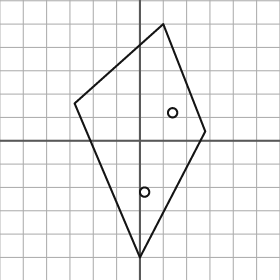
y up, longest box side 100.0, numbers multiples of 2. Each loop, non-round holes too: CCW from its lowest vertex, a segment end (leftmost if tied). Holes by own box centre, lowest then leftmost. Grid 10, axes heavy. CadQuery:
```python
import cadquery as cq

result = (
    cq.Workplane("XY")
    .moveTo(0.0, -50.0)
    .lineTo(28.0, 4.0)
    .lineTo(10.0, 50.0)
    .lineTo(-28.0, 16.0)
    .close()
    .moveTo(2.0, -22.0)
    .circle(2.0)
    .moveTo(14.0, 12.0)
    .circle(2.0)
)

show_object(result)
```